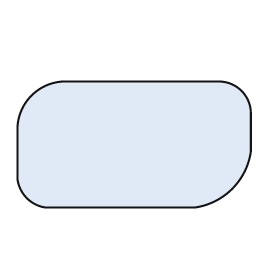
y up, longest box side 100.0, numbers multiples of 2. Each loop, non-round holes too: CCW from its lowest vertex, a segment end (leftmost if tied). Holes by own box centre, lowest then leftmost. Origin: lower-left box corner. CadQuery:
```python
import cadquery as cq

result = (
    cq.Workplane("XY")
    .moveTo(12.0, 0.0)
    .lineTo(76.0, 0.0)
    .threePointArc((92.0, 8.0), (100.0, 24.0))
    .lineTo(100.0, 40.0)
    .threePointArc((96.0, 50.0), (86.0, 54.0))
    .lineTo(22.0, 54.0)
    .threePointArc((6.0, 48.0), (0.0, 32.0))
    .lineTo(0.0, 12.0)
    .threePointArc((4.0, 4.0), (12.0, 0.0))
    .close()
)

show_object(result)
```